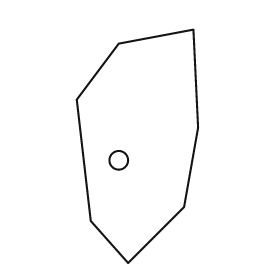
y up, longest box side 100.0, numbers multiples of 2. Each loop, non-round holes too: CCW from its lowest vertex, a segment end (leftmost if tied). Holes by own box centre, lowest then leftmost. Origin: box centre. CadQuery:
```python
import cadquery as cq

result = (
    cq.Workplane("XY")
    .moveTo(-4.0, -50.0)
    .lineTo(20.0, -26.0)
    .lineTo(26.0, 8.0)
    .lineTo(24.0, 50.0)
    .lineTo(-8.0, 44.0)
    .lineTo(-26.0, 20.0)
    .lineTo(-20.0, -32.0)
    .close()
    .moveTo(-8.0, -6.0)
    .circle(4.0)
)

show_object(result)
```